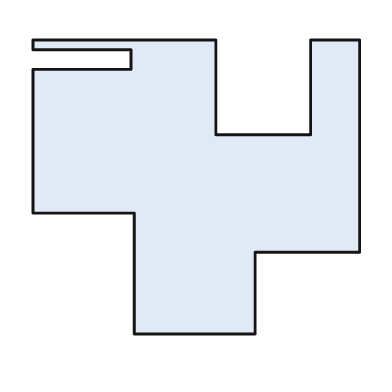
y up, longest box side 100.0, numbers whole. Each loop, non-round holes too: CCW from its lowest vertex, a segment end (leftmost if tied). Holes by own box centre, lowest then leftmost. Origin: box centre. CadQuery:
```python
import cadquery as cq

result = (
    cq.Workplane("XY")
    .moveTo(-19.0, -45.0)
    .lineTo(18.0, -45.0)
    .lineTo(18.0, -20.0)
    .lineTo(50.0, -20.0)
    .lineTo(50.0, 45.0)
    .lineTo(35.0, 45.0)
    .lineTo(35.0, 16.0)
    .lineTo(6.0, 16.0)
    .lineTo(6.0, 45.0)
    .lineTo(-50.0, 45.0)
    .lineTo(-50.0, 42.0)
    .lineTo(-20.0, 42.0)
    .lineTo(-20.0, 36.0)
    .lineTo(-50.0, 36.0)
    .lineTo(-50.0, -8.0)
    .lineTo(-19.0, -8.0)
    .close()
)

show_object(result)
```